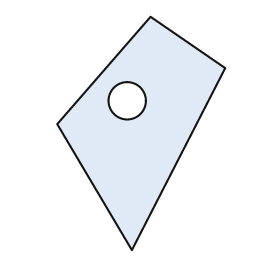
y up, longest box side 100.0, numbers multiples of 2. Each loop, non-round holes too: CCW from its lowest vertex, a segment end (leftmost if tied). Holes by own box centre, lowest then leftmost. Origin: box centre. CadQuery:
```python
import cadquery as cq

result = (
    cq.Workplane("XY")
    .moveTo(-4.0, -50.0)
    .lineTo(36.0, 28.0)
    .lineTo(4.0, 50.0)
    .lineTo(-36.0, 4.0)
    .close()
    .moveTo(-6.0, 14.0)
    .circle(8.0)
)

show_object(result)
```